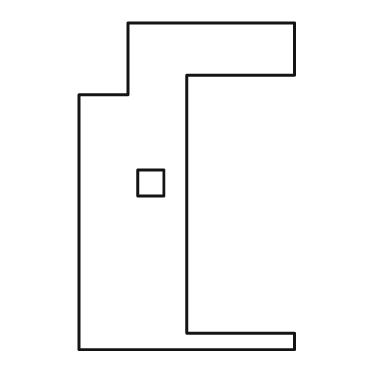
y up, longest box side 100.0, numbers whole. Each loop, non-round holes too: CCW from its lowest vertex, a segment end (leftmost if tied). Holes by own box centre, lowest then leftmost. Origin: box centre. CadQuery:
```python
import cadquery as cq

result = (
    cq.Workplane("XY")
    .moveTo(-33.0, -50.0)
    .lineTo(33.0, -50.0)
    .lineTo(33.0, -45.0)
    .lineTo(0.0, -45.0)
    .lineTo(0.0, 34.0)
    .lineTo(33.0, 34.0)
    .lineTo(33.0, 50.0)
    .lineTo(-18.0, 50.0)
    .lineTo(-18.0, 28.0)
    .lineTo(-33.0, 28.0)
    .close()
    .moveTo(-15.0, -3.0)
    .lineTo(-7.0, -3.0)
    .lineTo(-7.0, 5.0)
    .lineTo(-15.0, 5.0)
    .close()
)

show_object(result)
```